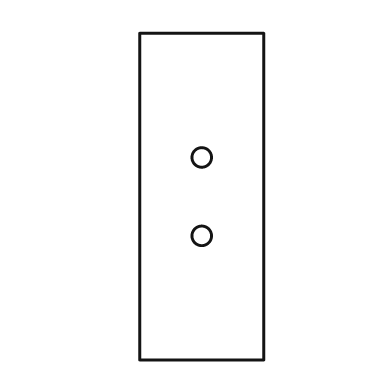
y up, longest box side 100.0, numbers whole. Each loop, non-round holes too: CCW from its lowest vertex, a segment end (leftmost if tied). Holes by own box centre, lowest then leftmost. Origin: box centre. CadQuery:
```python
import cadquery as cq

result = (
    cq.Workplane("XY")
    .moveTo(-19.0, -50.0)
    .lineTo(19.0, -50.0)
    .lineTo(19.0, 50.0)
    .lineTo(-19.0, 50.0)
    .close()
    .moveTo(0.0, -12.0)
    .circle(3.0)
    .moveTo(0.0, 12.0)
    .circle(3.0)
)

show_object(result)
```